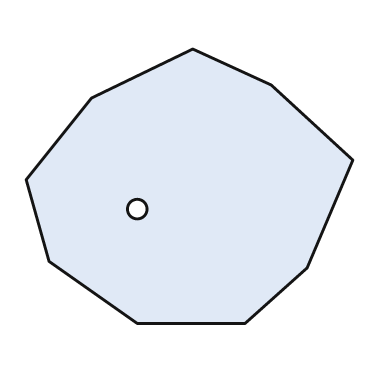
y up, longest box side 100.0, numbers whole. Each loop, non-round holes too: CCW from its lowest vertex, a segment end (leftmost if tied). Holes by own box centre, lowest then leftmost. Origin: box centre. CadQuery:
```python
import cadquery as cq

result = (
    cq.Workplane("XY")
    .moveTo(-16.0, -42.0)
    .lineTo(17.0, -42.0)
    .lineTo(36.0, -25.0)
    .lineTo(50.0, 8.0)
    .lineTo(25.0, 31.0)
    .lineTo(1.0, 42.0)
    .lineTo(-30.0, 27.0)
    .lineTo(-50.0, 2.0)
    .lineTo(-43.0, -23.0)
    .close()
    .moveTo(-16.0, -7.0)
    .circle(3.0)
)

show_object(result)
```